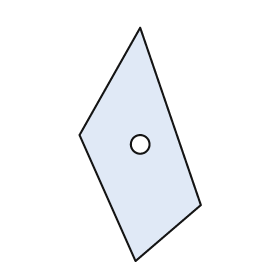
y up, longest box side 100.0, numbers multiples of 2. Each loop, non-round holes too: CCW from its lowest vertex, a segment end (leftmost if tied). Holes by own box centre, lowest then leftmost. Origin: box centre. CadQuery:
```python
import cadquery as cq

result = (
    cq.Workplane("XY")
    .moveTo(-2.0, -50.0)
    .lineTo(26.0, -26.0)
    .lineTo(0.0, 50.0)
    .lineTo(-26.0, 4.0)
    .close()
    .moveTo(0.0, 0.0)
    .circle(4.0)
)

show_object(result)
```